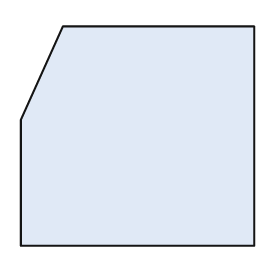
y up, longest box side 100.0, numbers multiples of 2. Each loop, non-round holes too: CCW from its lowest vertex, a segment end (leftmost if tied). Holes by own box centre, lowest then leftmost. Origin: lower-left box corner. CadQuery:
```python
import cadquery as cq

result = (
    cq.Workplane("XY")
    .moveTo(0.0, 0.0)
    .lineTo(100.0, 0.0)
    .lineTo(100.0, 94.0)
    .lineTo(18.0, 94.0)
    .lineTo(0.0, 54.0)
    .close()
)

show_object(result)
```